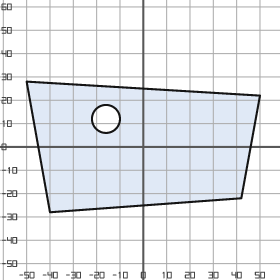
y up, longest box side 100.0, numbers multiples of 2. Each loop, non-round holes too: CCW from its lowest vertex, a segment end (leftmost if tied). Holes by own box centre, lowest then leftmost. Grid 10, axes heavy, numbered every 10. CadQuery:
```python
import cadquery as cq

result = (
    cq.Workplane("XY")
    .moveTo(-40.0, -28.0)
    .lineTo(42.0, -22.0)
    .lineTo(50.0, 22.0)
    .lineTo(-50.0, 28.0)
    .close()
    .moveTo(-16.0, 12.0)
    .circle(6.0)
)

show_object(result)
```